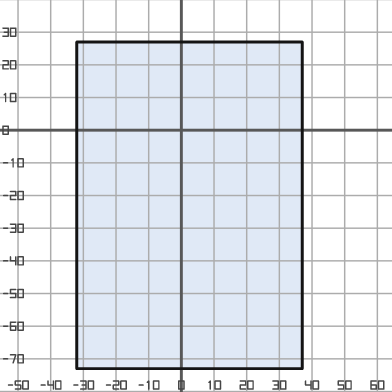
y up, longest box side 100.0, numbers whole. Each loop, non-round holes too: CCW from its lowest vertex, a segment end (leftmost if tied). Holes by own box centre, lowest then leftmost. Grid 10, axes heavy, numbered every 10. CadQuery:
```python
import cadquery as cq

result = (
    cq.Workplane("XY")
    .moveTo(-32.0, -73.0)
    .lineTo(37.0, -73.0)
    .lineTo(37.0, 27.0)
    .lineTo(-32.0, 27.0)
    .close()
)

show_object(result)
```